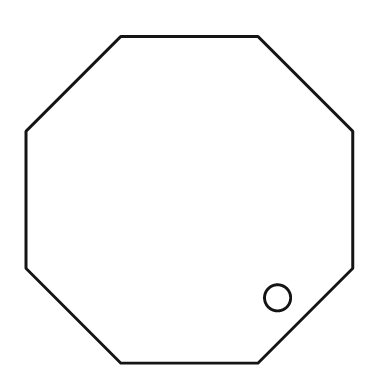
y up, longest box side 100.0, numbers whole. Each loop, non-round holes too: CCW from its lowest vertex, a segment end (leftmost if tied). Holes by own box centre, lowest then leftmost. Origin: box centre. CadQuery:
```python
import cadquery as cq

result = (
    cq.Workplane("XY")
    .moveTo(-21.0, -50.0)
    .lineTo(21.0, -50.0)
    .lineTo(50.0, -21.0)
    .lineTo(50.0, 21.0)
    .lineTo(21.0, 50.0)
    .lineTo(-21.0, 50.0)
    .lineTo(-50.0, 21.0)
    .lineTo(-50.0, -21.0)
    .close()
    .moveTo(27.0, -30.0)
    .circle(4.0)
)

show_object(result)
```